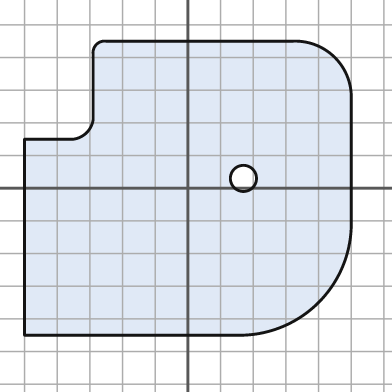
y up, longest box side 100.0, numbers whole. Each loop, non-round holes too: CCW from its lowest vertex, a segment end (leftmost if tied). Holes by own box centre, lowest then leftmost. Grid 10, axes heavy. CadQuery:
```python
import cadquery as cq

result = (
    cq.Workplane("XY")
    .moveTo(-50.0, -45.0)
    .lineTo(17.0, -45.0)
    .threePointArc((40.0, -35.0), (50.0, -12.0))
    .lineTo(50.0, 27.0)
    .threePointArc((45.0, 40.0), (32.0, 45.0))
    .lineTo(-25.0, 45.0)
    .threePointArc((-28.0, 44.0), (-29.0, 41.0))
    .lineTo(-29.0, 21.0)
    .threePointArc((-31.0, 17.0), (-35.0, 15.0))
    .lineTo(-50.0, 15.0)
    .close()
    .moveTo(17.0, 3.0)
    .circle(4.0)
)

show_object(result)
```